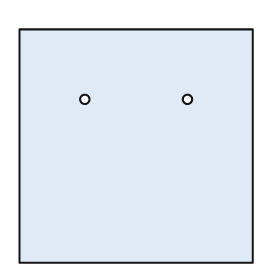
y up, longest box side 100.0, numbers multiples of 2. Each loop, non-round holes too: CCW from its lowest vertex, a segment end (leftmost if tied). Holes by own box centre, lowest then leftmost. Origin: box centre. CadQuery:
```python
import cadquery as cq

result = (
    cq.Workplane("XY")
    .moveTo(-50.0, -50.0)
    .lineTo(50.0, -50.0)
    .lineTo(50.0, 50.0)
    .lineTo(-50.0, 50.0)
    .close()
    .moveTo(-22.0, 20.0)
    .circle(2.0)
    .moveTo(22.0, 20.0)
    .circle(2.0)
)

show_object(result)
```